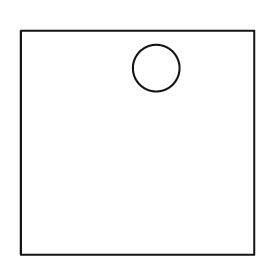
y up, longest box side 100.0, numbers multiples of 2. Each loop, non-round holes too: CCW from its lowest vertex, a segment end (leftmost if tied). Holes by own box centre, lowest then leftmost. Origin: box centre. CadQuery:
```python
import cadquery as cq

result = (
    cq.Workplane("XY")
    .moveTo(-50.0, -48.0)
    .lineTo(50.0, -48.0)
    .lineTo(50.0, 48.0)
    .lineTo(-50.0, 48.0)
    .close()
    .moveTo(8.0, 32.0)
    .circle(10.0)
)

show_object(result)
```